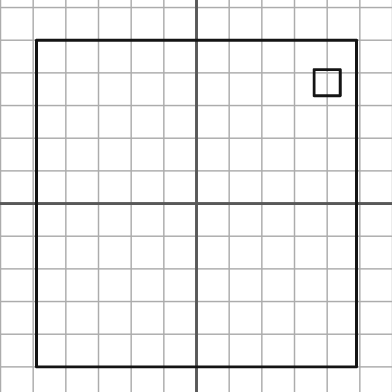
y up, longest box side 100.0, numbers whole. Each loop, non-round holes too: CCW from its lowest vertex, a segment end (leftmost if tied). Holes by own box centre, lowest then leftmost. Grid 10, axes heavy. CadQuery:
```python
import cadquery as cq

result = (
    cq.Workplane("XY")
    .moveTo(-49.0, -50.0)
    .lineTo(49.0, -50.0)
    .lineTo(49.0, 50.0)
    .lineTo(-49.0, 50.0)
    .close()
    .moveTo(36.0, 33.0)
    .lineTo(44.0, 33.0)
    .lineTo(44.0, 41.0)
    .lineTo(36.0, 41.0)
    .close()
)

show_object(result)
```